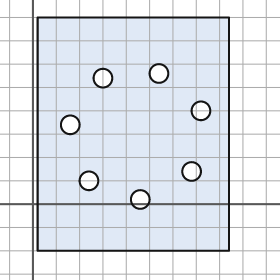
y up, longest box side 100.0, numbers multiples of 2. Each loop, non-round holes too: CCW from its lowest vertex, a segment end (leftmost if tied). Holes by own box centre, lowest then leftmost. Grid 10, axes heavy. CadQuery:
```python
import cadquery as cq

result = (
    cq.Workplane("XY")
    .moveTo(2.0, -20.0)
    .lineTo(84.0, -20.0)
    .lineTo(84.0, 80.0)
    .lineTo(2.0, 80.0)
    .close()
    .moveTo(46.0, 2.0)
    .circle(4.0)
    .moveTo(24.0, 10.0)
    .circle(4.0)
    .moveTo(68.0, 14.0)
    .circle(4.0)
    .moveTo(16.0, 34.0)
    .circle(4.0)
    .moveTo(72.0, 40.0)
    .circle(4.0)
    .moveTo(30.0, 54.0)
    .circle(4.0)
    .moveTo(54.0, 56.0)
    .circle(4.0)
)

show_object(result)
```